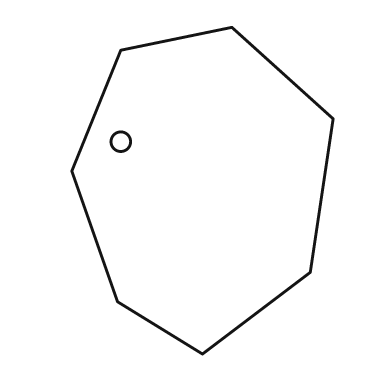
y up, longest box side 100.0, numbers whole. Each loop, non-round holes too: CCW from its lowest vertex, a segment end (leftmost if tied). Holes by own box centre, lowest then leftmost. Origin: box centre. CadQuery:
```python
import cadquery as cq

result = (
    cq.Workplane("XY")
    .moveTo(0.0, -50.0)
    .lineTo(33.0, -25.0)
    .lineTo(40.0, 22.0)
    .lineTo(9.0, 50.0)
    .lineTo(-25.0, 43.0)
    .lineTo(-40.0, 6.0)
    .lineTo(-26.0, -34.0)
    .close()
    .moveTo(-25.0, 15.0)
    .circle(3.0)
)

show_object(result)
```